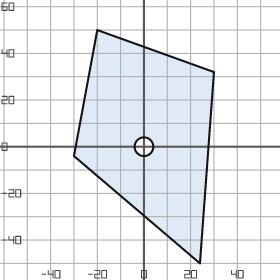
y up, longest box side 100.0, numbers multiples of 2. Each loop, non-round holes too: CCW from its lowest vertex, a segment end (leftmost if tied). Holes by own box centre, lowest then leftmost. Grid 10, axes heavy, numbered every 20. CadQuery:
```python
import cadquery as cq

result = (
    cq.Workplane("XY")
    .moveTo(24.0, -50.0)
    .lineTo(30.0, 32.0)
    .lineTo(-20.0, 50.0)
    .lineTo(-30.0, -4.0)
    .close()
    .moveTo(0.0, 0.0)
    .circle(4.0)
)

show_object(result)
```